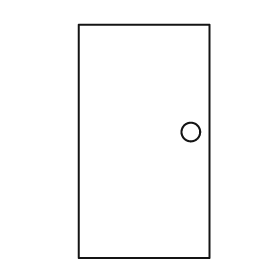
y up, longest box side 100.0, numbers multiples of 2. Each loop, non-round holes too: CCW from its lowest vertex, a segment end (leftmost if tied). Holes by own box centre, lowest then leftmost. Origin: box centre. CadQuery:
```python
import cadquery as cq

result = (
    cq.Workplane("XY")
    .moveTo(-28.0, -50.0)
    .lineTo(28.0, -50.0)
    .lineTo(28.0, 50.0)
    .lineTo(-28.0, 50.0)
    .close()
    .moveTo(20.0, 4.0)
    .circle(4.0)
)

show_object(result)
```